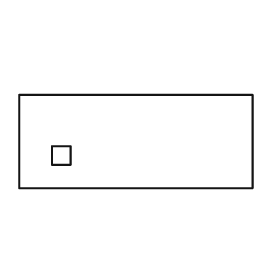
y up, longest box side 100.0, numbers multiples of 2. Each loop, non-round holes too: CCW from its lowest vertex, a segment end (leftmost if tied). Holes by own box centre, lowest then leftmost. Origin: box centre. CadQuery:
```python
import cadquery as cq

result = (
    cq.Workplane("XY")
    .moveTo(-50.0, -20.0)
    .lineTo(50.0, -20.0)
    .lineTo(50.0, 20.0)
    .lineTo(-50.0, 20.0)
    .close()
    .moveTo(-36.0, -10.0)
    .lineTo(-28.0, -10.0)
    .lineTo(-28.0, -2.0)
    .lineTo(-36.0, -2.0)
    .close()
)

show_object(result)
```